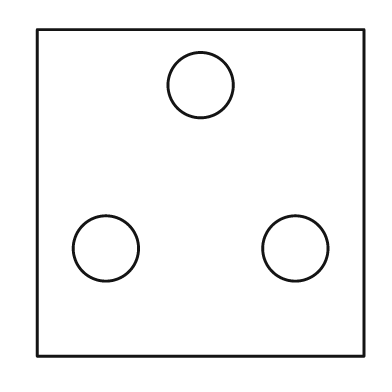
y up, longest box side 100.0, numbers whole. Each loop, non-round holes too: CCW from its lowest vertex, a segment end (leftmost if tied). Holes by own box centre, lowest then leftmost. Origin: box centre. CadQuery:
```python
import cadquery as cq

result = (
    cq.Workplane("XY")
    .moveTo(-50.0, -50.0)
    .lineTo(50.0, -50.0)
    .lineTo(50.0, 50.0)
    .lineTo(-50.0, 50.0)
    .close()
    .moveTo(-29.0, -17.0)
    .circle(10.0)
    .moveTo(29.0, -17.0)
    .circle(10.0)
    .moveTo(0.0, 33.0)
    .circle(10.0)
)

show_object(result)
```